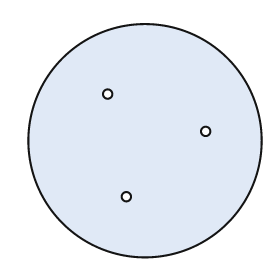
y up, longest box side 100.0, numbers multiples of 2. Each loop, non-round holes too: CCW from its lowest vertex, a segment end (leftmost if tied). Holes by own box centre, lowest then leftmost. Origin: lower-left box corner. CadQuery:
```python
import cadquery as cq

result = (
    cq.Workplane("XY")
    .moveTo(50.0, 50.0)
    .circle(50.0)
    .moveTo(42.0, 26.0)
    .circle(2.0)
    .moveTo(76.0, 54.0)
    .circle(2.0)
    .moveTo(34.0, 70.0)
    .circle(2.0)
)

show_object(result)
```